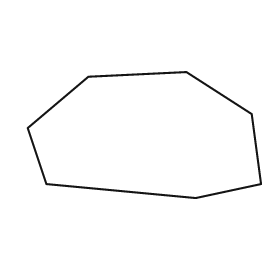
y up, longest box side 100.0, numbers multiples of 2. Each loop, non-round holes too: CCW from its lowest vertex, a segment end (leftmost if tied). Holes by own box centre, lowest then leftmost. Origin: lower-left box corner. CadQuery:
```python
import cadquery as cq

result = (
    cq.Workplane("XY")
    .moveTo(72.0, 0.0)
    .lineTo(100.0, 6.0)
    .lineTo(96.0, 36.0)
    .lineTo(68.0, 54.0)
    .lineTo(26.0, 52.0)
    .lineTo(0.0, 30.0)
    .lineTo(8.0, 6.0)
    .close()
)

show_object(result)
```